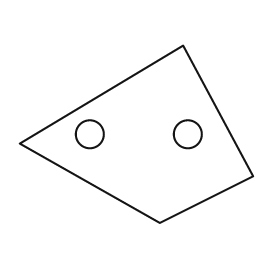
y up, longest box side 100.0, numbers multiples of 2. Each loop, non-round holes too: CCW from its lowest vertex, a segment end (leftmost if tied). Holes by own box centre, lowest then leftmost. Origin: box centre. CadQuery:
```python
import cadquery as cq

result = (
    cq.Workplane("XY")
    .moveTo(10.0, -38.0)
    .lineTo(50.0, -18.0)
    .lineTo(20.0, 38.0)
    .lineTo(-50.0, -4.0)
    .close()
    .moveTo(-20.0, 0.0)
    .circle(6.0)
    .moveTo(22.0, 0.0)
    .circle(6.0)
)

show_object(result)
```